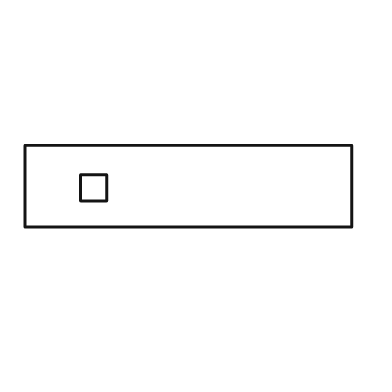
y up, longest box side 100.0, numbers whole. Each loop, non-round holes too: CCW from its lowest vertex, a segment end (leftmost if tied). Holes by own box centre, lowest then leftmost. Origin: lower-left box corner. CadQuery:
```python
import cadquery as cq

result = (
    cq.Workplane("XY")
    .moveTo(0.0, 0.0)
    .lineTo(100.0, 0.0)
    .lineTo(100.0, 25.0)
    .lineTo(0.0, 25.0)
    .close()
    .moveTo(17.0, 8.0)
    .lineTo(25.0, 8.0)
    .lineTo(25.0, 16.0)
    .lineTo(17.0, 16.0)
    .close()
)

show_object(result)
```